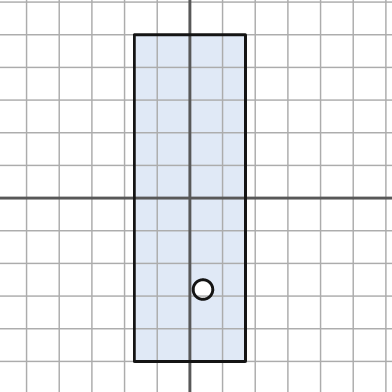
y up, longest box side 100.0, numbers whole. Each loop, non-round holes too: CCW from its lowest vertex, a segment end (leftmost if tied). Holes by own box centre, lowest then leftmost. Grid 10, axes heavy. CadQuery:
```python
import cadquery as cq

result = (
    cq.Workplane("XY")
    .moveTo(-17.0, -50.0)
    .lineTo(17.0, -50.0)
    .lineTo(17.0, 50.0)
    .lineTo(-17.0, 50.0)
    .close()
    .moveTo(4.0, -28.0)
    .circle(3.0)
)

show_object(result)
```